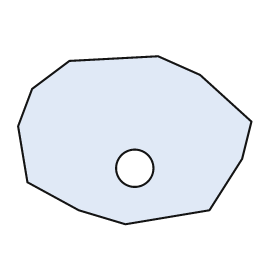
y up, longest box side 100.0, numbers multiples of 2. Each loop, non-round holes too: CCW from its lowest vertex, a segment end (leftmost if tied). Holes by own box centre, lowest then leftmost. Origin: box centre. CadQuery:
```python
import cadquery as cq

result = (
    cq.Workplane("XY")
    .moveTo(-4.0, -36.0)
    .lineTo(32.0, -30.0)
    .lineTo(46.0, -8.0)
    .lineTo(50.0, 8.0)
    .lineTo(28.0, 28.0)
    .lineTo(10.0, 36.0)
    .lineTo(-28.0, 34.0)
    .lineTo(-44.0, 22.0)
    .lineTo(-50.0, 6.0)
    .lineTo(-46.0, -18.0)
    .lineTo(-24.0, -30.0)
    .close()
    .moveTo(0.0, -12.0)
    .circle(8.0)
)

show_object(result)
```